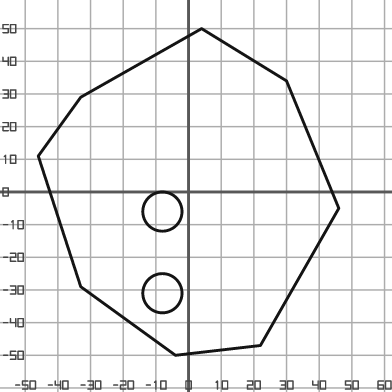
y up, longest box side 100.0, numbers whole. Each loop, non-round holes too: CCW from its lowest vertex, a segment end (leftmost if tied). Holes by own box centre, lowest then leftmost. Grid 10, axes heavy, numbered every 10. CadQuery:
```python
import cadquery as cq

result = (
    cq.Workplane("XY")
    .moveTo(-4.0, -50.0)
    .lineTo(22.0, -47.0)
    .lineTo(46.0, -5.0)
    .lineTo(30.0, 34.0)
    .lineTo(4.0, 50.0)
    .lineTo(-33.0, 29.0)
    .lineTo(-46.0, 11.0)
    .lineTo(-33.0, -29.0)
    .close()
    .moveTo(-8.0, -31.0)
    .circle(6.0)
    .moveTo(-8.0, -6.0)
    .circle(6.0)
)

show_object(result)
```